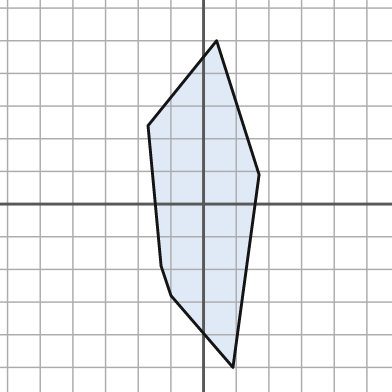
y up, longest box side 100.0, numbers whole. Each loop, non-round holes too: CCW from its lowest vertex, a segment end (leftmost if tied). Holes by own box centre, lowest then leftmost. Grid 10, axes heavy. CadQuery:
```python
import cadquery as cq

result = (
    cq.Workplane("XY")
    .moveTo(9.0, -50.0)
    .lineTo(17.0, 9.0)
    .lineTo(4.0, 50.0)
    .lineTo(-17.0, 24.0)
    .lineTo(-13.0, -19.0)
    .lineTo(-10.0, -28.0)
    .close()
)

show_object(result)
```